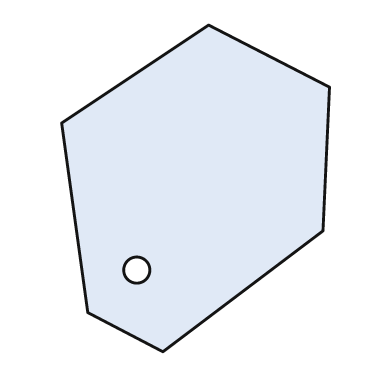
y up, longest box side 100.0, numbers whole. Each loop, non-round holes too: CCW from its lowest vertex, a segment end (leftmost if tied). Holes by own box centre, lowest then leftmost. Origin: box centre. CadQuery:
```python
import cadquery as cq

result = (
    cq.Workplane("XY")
    .moveTo(-10.0, -50.0)
    .lineTo(39.0, -13.0)
    .lineTo(41.0, 31.0)
    .lineTo(4.0, 50.0)
    .lineTo(-41.0, 20.0)
    .lineTo(-33.0, -38.0)
    .close()
    .moveTo(-18.0, -25.0)
    .circle(4.0)
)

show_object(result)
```